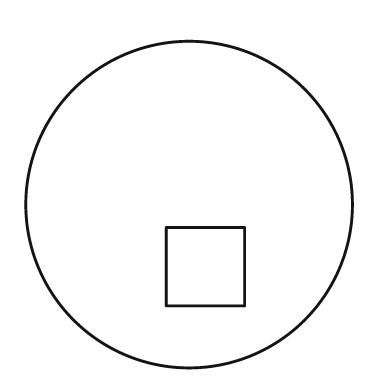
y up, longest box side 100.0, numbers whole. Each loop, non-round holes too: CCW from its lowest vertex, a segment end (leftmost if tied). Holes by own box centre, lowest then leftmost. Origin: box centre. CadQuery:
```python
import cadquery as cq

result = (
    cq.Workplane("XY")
    .moveTo(0.0, 0.0)
    .circle(50.0)
    .moveTo(-7.0, -31.0)
    .lineTo(17.0, -31.0)
    .lineTo(17.0, -7.0)
    .lineTo(-7.0, -7.0)
    .close()
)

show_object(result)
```